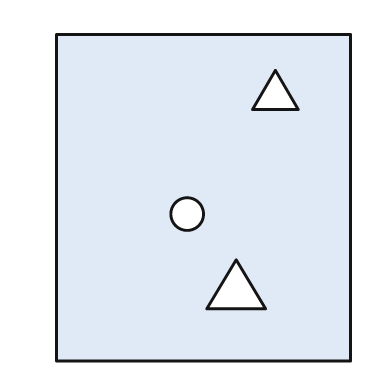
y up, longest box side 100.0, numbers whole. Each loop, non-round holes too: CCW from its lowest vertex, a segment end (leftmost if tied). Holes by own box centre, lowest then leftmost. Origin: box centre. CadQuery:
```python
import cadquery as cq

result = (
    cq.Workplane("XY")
    .moveTo(-45.0, -50.0)
    .lineTo(45.0, -50.0)
    .lineTo(45.0, 50.0)
    .lineTo(-45.0, 50.0)
    .close()
    .moveTo(1.0, -34.0)
    .lineTo(19.0, -34.0)
    .lineTo(10.0, -19.0)
    .close()
    .moveTo(-5.0, -5.0)
    .circle(5.0)
    .moveTo(15.0, 27.0)
    .lineTo(29.0, 27.0)
    .lineTo(22.0, 39.0)
    .close()
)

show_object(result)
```